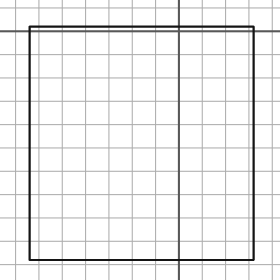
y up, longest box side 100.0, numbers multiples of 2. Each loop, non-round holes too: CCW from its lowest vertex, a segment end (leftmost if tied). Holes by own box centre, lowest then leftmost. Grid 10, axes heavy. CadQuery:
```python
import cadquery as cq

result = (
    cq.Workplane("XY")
    .moveTo(-64.0, -98.0)
    .lineTo(32.0, -98.0)
    .lineTo(32.0, 2.0)
    .lineTo(-64.0, 2.0)
    .close()
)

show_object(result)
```